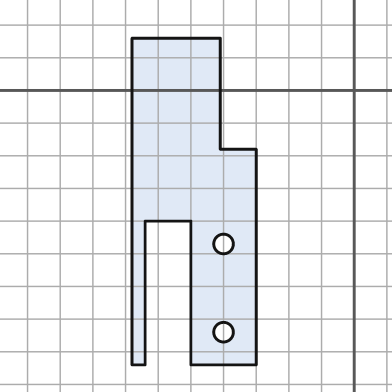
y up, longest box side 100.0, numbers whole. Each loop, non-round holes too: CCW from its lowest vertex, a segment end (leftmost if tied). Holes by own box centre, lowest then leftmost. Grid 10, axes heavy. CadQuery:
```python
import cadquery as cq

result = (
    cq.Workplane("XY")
    .moveTo(-68.0, -84.0)
    .lineTo(-64.0, -84.0)
    .lineTo(-64.0, -40.0)
    .lineTo(-50.0, -40.0)
    .lineTo(-50.0, -84.0)
    .lineTo(-30.0, -84.0)
    .lineTo(-30.0, -18.0)
    .lineTo(-41.0, -18.0)
    .lineTo(-41.0, 16.0)
    .lineTo(-68.0, 16.0)
    .close()
    .moveTo(-40.0, -74.0)
    .circle(3.0)
    .moveTo(-40.0, -47.0)
    .circle(3.0)
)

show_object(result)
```